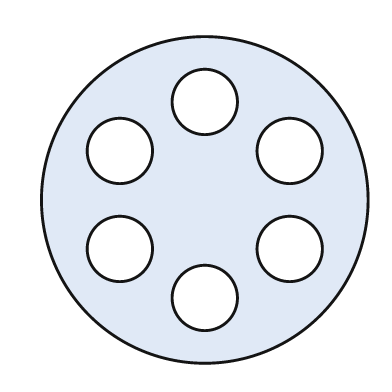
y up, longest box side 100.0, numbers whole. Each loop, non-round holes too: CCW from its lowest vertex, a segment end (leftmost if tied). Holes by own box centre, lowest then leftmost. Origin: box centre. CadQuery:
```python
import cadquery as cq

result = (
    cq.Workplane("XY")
    .moveTo(0.0, 0.0)
    .circle(50.0)
    .moveTo(0.0, -30.0)
    .circle(10.0)
    .moveTo(-26.0, -15.0)
    .circle(10.0)
    .moveTo(26.0, -15.0)
    .circle(10.0)
    .moveTo(-26.0, 15.0)
    .circle(10.0)
    .moveTo(26.0, 15.0)
    .circle(10.0)
    .moveTo(0.0, 30.0)
    .circle(10.0)
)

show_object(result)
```